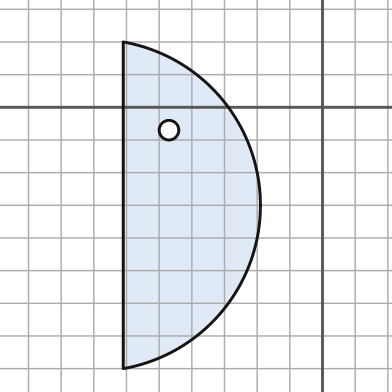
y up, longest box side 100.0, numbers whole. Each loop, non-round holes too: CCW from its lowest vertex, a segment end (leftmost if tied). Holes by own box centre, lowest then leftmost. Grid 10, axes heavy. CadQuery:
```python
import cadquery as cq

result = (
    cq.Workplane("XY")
    .moveTo(-61.0, -80.0)
    .threePointArc((-19.0, -30.0), (-61.0, 20.0))
    .close()
    .moveTo(-47.0, -7.0)
    .circle(3.0)
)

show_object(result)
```